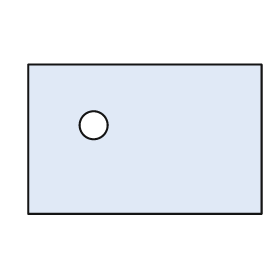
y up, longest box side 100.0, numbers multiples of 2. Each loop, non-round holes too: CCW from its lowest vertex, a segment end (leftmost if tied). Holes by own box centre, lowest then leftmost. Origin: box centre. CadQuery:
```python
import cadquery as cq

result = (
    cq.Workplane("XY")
    .moveTo(-50.0, -32.0)
    .lineTo(50.0, -32.0)
    .lineTo(50.0, 32.0)
    .lineTo(-50.0, 32.0)
    .close()
    .moveTo(-22.0, 6.0)
    .circle(6.0)
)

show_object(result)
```